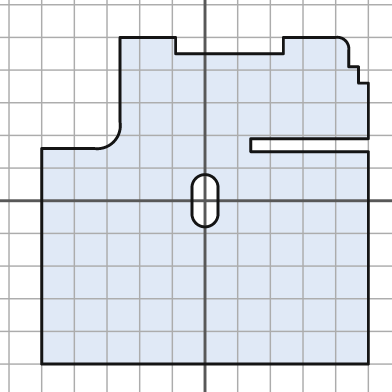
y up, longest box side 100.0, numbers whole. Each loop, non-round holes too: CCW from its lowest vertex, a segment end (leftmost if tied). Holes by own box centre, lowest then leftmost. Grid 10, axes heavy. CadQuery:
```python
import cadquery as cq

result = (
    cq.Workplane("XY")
    .moveTo(-50.0, -50.0)
    .lineTo(50.0, -50.0)
    .lineTo(50.0, 15.0)
    .lineTo(14.0, 15.0)
    .lineTo(14.0, 19.0)
    .lineTo(50.0, 19.0)
    .lineTo(50.0, 36.0)
    .lineTo(47.0, 36.0)
    .lineTo(47.0, 41.0)
    .lineTo(44.0, 41.0)
    .lineTo(44.0, 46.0)
    .threePointArc((43.0, 49.0), (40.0, 50.0))
    .lineTo(24.0, 50.0)
    .lineTo(24.0, 45.0)
    .lineTo(-9.0, 45.0)
    .lineTo(-9.0, 50.0)
    .lineTo(-26.0, 50.0)
    .lineTo(-26.0, 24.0)
    .threePointArc((-28.0, 18.0), (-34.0, 16.0))
    .lineTo(-50.0, 16.0)
    .close()
    .moveTo(-4.0, -4.0)
    .threePointArc((0.0, -8.0), (4.0, -4.0))
    .lineTo(4.0, 4.0)
    .threePointArc((0.0, 8.0), (-4.0, 4.0))
    .close()
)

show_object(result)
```